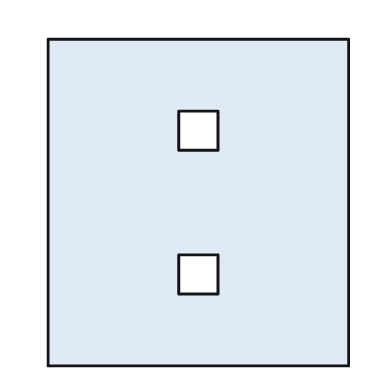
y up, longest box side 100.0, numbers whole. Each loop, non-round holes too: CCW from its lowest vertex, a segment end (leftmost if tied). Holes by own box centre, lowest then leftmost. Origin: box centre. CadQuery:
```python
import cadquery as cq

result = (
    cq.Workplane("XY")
    .moveTo(-46.0, -50.0)
    .lineTo(46.0, -50.0)
    .lineTo(46.0, 50.0)
    .lineTo(-46.0, 50.0)
    .close()
    .moveTo(-6.0, -28.0)
    .lineTo(6.0, -28.0)
    .lineTo(6.0, -16.0)
    .lineTo(-6.0, -16.0)
    .close()
    .moveTo(-6.0, 16.0)
    .lineTo(6.0, 16.0)
    .lineTo(6.0, 28.0)
    .lineTo(-6.0, 28.0)
    .close()
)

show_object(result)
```